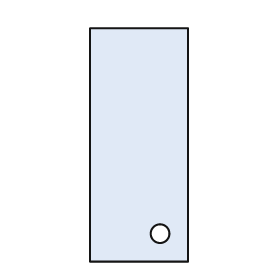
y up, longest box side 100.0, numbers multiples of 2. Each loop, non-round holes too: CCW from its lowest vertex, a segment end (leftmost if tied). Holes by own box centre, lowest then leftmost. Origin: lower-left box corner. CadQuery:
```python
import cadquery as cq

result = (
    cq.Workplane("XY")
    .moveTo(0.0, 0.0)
    .lineTo(42.0, 0.0)
    .lineTo(42.0, 100.0)
    .lineTo(0.0, 100.0)
    .close()
    .moveTo(30.0, 12.0)
    .circle(4.0)
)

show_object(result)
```